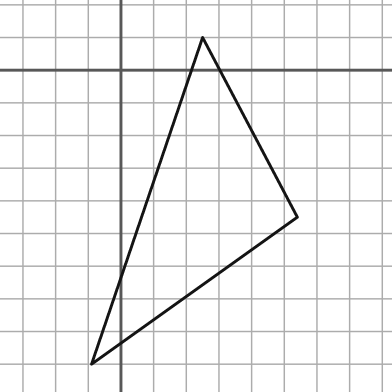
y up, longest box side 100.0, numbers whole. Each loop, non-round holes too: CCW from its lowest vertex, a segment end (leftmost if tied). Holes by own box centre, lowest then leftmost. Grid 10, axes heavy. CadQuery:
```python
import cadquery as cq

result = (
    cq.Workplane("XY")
    .moveTo(-9.0, -90.0)
    .lineTo(54.0, -45.0)
    .lineTo(25.0, 10.0)
    .close()
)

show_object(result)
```